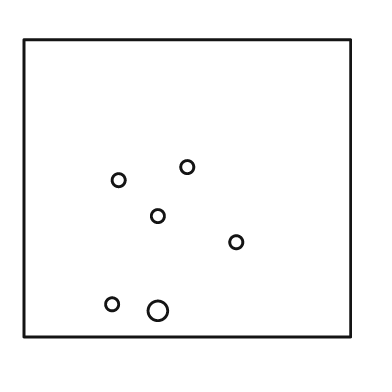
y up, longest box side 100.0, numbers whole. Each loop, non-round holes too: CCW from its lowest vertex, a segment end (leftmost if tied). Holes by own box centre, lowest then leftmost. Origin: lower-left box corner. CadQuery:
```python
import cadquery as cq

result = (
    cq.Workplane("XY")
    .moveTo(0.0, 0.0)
    .lineTo(100.0, 0.0)
    .lineTo(100.0, 91.0)
    .lineTo(0.0, 91.0)
    .close()
    .moveTo(41.0, 8.0)
    .circle(3.0)
    .moveTo(27.0, 10.0)
    .circle(2.0)
    .moveTo(65.0, 29.0)
    .circle(2.0)
    .moveTo(41.0, 37.0)
    .circle(2.0)
    .moveTo(29.0, 48.0)
    .circle(2.0)
    .moveTo(50.0, 52.0)
    .circle(2.0)
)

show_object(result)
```